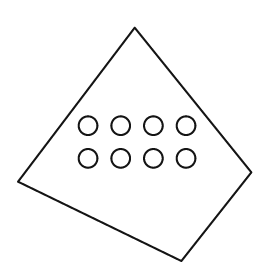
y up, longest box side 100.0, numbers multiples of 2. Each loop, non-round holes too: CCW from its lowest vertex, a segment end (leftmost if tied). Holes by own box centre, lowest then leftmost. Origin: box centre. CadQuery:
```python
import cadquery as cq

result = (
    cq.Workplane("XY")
    .moveTo(20.0, -50.0)
    .lineTo(50.0, -12.0)
    .lineTo(0.0, 50.0)
    .lineTo(-50.0, -16.0)
    .close()
    .moveTo(-20.0, -6.0)
    .circle(4.0)
    .moveTo(-6.0, -6.0)
    .circle(4.0)
    .moveTo(8.0, -6.0)
    .circle(4.0)
    .moveTo(22.0, -6.0)
    .circle(4.0)
    .moveTo(-20.0, 8.0)
    .circle(4.0)
    .moveTo(-6.0, 8.0)
    .circle(4.0)
    .moveTo(8.0, 8.0)
    .circle(4.0)
    .moveTo(22.0, 8.0)
    .circle(4.0)
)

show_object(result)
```